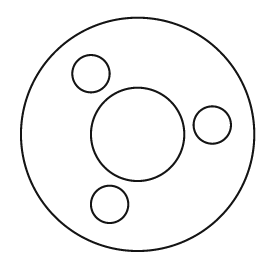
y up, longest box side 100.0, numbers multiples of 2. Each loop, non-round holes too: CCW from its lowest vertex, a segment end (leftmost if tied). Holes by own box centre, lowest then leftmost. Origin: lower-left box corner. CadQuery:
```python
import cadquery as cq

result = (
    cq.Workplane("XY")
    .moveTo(50.0, 50.0)
    .circle(50.0)
    .moveTo(38.0, 20.0)
    .circle(8.0)
    .moveTo(50.0, 50.0)
    .circle(20.0)
    .moveTo(82.0, 54.0)
    .circle(8.0)
    .moveTo(30.0, 76.0)
    .circle(8.0)
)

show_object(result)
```